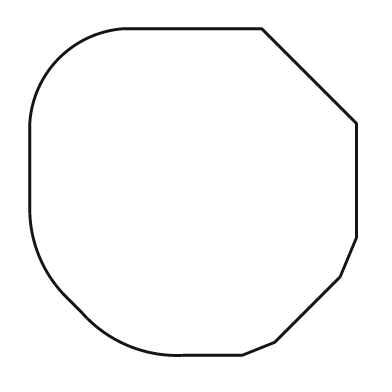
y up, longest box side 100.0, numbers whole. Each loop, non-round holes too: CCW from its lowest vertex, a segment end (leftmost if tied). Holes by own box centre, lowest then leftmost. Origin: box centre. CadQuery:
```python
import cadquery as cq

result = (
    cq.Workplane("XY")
    .moveTo(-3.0, -50.0)
    .lineTo(15.0, -50.0)
    .lineTo(25.0, -46.0)
    .lineTo(45.0, -26.0)
    .lineTo(50.0, -14.0)
    .lineTo(50.0, 21.0)
    .lineTo(21.0, 50.0)
    .lineTo(-21.0, 50.0)
    .threePointArc((-41.0, 41.0), (-50.0, 21.0))
    .lineTo(-50.0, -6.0)
    .threePointArc((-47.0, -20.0), (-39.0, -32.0))
    .lineTo(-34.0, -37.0)
    .threePointArc((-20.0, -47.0), (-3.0, -50.0))
    .close()
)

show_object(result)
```